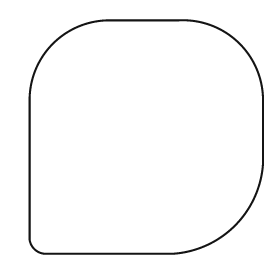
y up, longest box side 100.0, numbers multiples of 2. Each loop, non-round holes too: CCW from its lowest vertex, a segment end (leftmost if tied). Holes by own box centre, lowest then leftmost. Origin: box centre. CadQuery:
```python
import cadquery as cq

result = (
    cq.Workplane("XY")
    .moveTo(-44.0, -50.0)
    .lineTo(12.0, -50.0)
    .threePointArc((38.0, -38.0), (50.0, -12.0))
    .lineTo(50.0, 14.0)
    .threePointArc((40.0, 40.0), (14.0, 50.0))
    .lineTo(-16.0, 50.0)
    .threePointArc((-40.0, 40.0), (-50.0, 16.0))
    .lineTo(-50.0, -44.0)
    .threePointArc((-48.0, -48.0), (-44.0, -50.0))
    .close()
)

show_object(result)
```